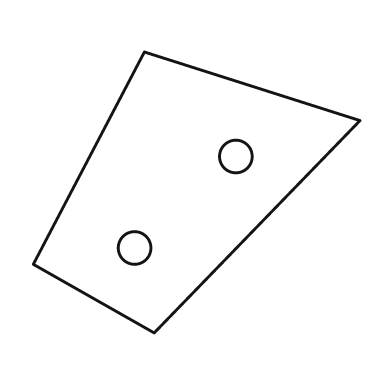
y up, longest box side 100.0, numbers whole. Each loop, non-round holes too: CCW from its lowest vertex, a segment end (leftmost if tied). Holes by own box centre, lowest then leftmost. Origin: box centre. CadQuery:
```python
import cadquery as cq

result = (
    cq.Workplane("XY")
    .moveTo(-13.0, -43.0)
    .lineTo(50.0, 22.0)
    .lineTo(-16.0, 43.0)
    .lineTo(-50.0, -22.0)
    .close()
    .moveTo(-19.0, -17.0)
    .circle(5.0)
    .moveTo(12.0, 11.0)
    .circle(5.0)
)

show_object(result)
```